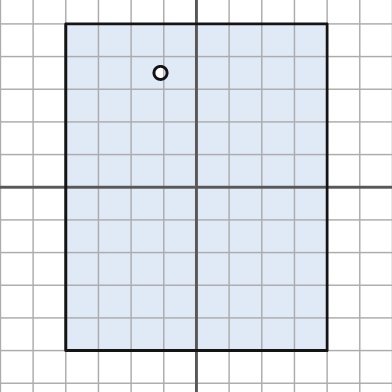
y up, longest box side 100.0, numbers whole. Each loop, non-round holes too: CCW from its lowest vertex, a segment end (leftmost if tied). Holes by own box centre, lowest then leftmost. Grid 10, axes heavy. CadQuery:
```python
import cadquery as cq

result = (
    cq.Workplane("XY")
    .moveTo(-40.0, -50.0)
    .lineTo(40.0, -50.0)
    .lineTo(40.0, 50.0)
    .lineTo(-40.0, 50.0)
    .close()
    .moveTo(-11.0, 35.0)
    .circle(2.0)
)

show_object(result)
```